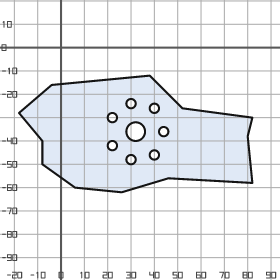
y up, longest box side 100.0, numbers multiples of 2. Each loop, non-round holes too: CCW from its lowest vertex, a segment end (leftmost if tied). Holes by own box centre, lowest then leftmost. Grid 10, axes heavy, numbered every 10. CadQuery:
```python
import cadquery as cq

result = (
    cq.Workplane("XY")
    .moveTo(26.0, -62.0)
    .lineTo(46.0, -56.0)
    .lineTo(82.0, -58.0)
    .lineTo(80.0, -38.0)
    .lineTo(82.0, -30.0)
    .lineTo(52.0, -26.0)
    .lineTo(38.0, -12.0)
    .lineTo(-4.0, -16.0)
    .lineTo(-18.0, -28.0)
    .lineTo(-8.0, -40.0)
    .lineTo(-8.0, -50.0)
    .lineTo(6.0, -60.0)
    .close()
    .moveTo(30.0, -48.0)
    .circle(2.0)
    .moveTo(40.0, -46.0)
    .circle(2.0)
    .moveTo(22.0, -42.0)
    .circle(2.0)
    .moveTo(32.0, -36.0)
    .circle(4.0)
    .moveTo(44.0, -36.0)
    .circle(2.0)
    .moveTo(22.0, -30.0)
    .circle(2.0)
    .moveTo(40.0, -26.0)
    .circle(2.0)
    .moveTo(30.0, -24.0)
    .circle(2.0)
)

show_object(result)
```